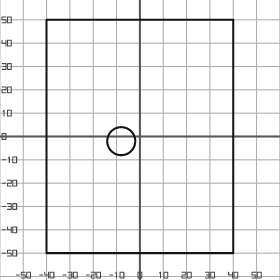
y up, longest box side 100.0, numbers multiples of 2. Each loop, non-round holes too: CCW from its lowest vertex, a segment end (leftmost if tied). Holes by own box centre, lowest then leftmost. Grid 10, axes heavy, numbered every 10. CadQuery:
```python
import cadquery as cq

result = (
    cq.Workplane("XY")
    .moveTo(-40.0, -50.0)
    .lineTo(40.0, -50.0)
    .lineTo(40.0, 50.0)
    .lineTo(-40.0, 50.0)
    .close()
    .moveTo(-8.0, -2.0)
    .circle(6.0)
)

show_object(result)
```